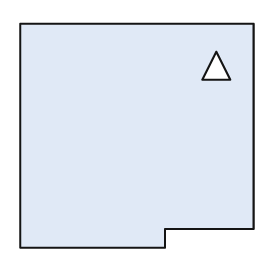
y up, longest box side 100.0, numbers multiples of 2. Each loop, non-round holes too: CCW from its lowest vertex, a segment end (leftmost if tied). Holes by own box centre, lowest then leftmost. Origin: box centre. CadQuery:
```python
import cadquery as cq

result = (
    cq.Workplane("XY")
    .moveTo(-50.0, -48.0)
    .lineTo(12.0, -48.0)
    .lineTo(12.0, -40.0)
    .lineTo(50.0, -40.0)
    .lineTo(50.0, 48.0)
    .lineTo(-50.0, 48.0)
    .close()
    .moveTo(28.0, 24.0)
    .lineTo(40.0, 24.0)
    .lineTo(34.0, 36.0)
    .close()
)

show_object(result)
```